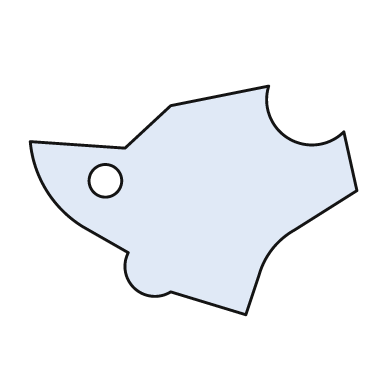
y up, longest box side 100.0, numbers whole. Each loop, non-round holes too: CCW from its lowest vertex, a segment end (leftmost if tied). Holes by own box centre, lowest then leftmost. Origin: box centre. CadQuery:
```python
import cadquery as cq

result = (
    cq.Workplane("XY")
    .moveTo(16.0, -35.0)
    .lineTo(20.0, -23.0)
    .threePointArc((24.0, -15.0), (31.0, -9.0))
    .lineTo(50.0, 3.0)
    .lineTo(46.0, 21.0)
    .threePointArc((29.0, 19.0), (23.0, 35.0))
    .lineTo(-7.0, 29.0)
    .lineTo(-21.0, 16.0)
    .lineTo(-50.0, 18.0)
    .threePointArc((-45.0, 3.0), (-34.0, -8.0))
    .lineTo(-20.0, -16.0)
    .threePointArc((-18.0, -27.0), (-7.0, -28.0))
    .close()
    .moveTo(-27.0, 6.0)
    .circle(5.0)
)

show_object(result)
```